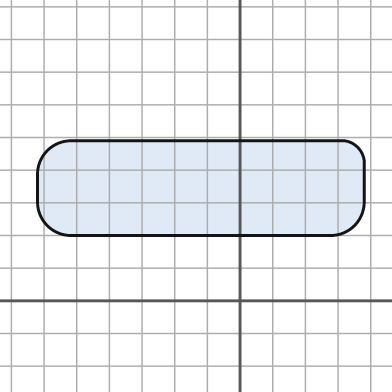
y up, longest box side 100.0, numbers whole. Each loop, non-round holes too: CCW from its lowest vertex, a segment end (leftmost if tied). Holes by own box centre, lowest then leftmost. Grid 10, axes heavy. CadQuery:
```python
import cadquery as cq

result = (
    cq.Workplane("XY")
    .moveTo(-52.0, 20.0)
    .lineTo(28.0, 20.0)
    .threePointArc((35.0, 23.0), (38.0, 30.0))
    .lineTo(38.0, 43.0)
    .threePointArc((36.0, 47.0), (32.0, 49.0))
    .lineTo(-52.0, 49.0)
    .threePointArc((-59.0, 46.0), (-62.0, 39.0))
    .lineTo(-62.0, 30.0)
    .threePointArc((-59.0, 23.0), (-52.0, 20.0))
    .close()
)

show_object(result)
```